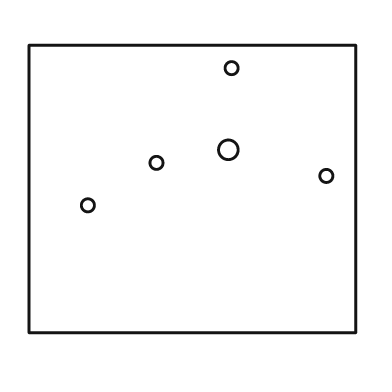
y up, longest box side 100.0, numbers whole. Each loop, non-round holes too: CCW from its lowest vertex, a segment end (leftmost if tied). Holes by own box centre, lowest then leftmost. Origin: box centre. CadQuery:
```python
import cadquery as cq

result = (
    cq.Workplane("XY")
    .moveTo(-50.0, -44.0)
    .lineTo(50.0, -44.0)
    .lineTo(50.0, 44.0)
    .lineTo(-50.0, 44.0)
    .close()
    .moveTo(-32.0, -5.0)
    .circle(2.0)
    .moveTo(41.0, 4.0)
    .circle(2.0)
    .moveTo(-11.0, 8.0)
    .circle(2.0)
    .moveTo(11.0, 12.0)
    .circle(3.0)
    .moveTo(12.0, 37.0)
    .circle(2.0)
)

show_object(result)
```